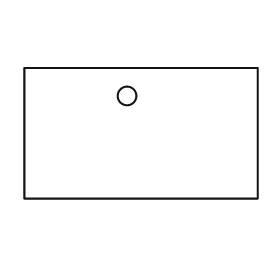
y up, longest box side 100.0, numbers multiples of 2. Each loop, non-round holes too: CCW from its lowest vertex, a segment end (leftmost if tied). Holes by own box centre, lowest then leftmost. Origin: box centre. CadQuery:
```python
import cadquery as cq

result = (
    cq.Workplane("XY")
    .moveTo(-50.0, -28.0)
    .lineTo(50.0, -28.0)
    .lineTo(50.0, 28.0)
    .lineTo(-50.0, 28.0)
    .close()
    .moveTo(-6.0, 16.0)
    .circle(4.0)
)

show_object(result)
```